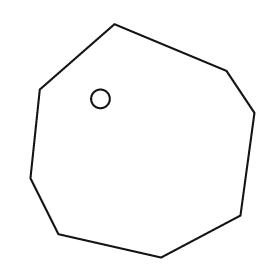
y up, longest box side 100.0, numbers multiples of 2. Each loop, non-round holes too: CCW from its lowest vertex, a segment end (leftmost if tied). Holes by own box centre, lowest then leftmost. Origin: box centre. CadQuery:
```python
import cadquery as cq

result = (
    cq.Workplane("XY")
    .moveTo(8.0, -50.0)
    .lineTo(42.0, -32.0)
    .lineTo(48.0, 12.0)
    .lineTo(36.0, 30.0)
    .lineTo(-12.0, 50.0)
    .lineTo(-44.0, 22.0)
    .lineTo(-48.0, -16.0)
    .lineTo(-36.0, -40.0)
    .close()
    .moveTo(-18.0, 18.0)
    .circle(4.0)
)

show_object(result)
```